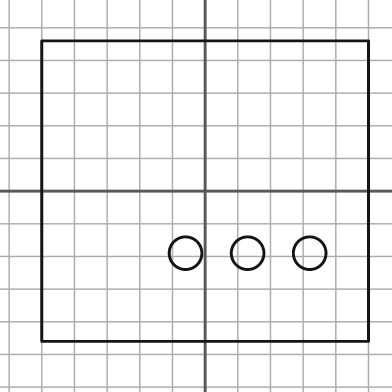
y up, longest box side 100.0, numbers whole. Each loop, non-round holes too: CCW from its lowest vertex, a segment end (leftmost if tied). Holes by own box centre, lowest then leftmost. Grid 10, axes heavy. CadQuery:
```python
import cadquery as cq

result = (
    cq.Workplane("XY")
    .moveTo(-50.0, -46.0)
    .lineTo(50.0, -46.0)
    .lineTo(50.0, 46.0)
    .lineTo(-50.0, 46.0)
    .close()
    .moveTo(-6.0, -19.0)
    .circle(5.0)
    .moveTo(13.0, -19.0)
    .circle(5.0)
    .moveTo(32.0, -19.0)
    .circle(5.0)
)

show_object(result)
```